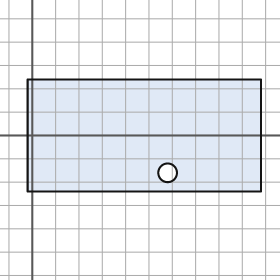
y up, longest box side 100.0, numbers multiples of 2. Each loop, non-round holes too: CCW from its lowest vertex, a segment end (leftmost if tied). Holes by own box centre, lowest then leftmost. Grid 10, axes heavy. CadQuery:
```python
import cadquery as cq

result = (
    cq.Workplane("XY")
    .moveTo(-2.0, -24.0)
    .lineTo(98.0, -24.0)
    .lineTo(98.0, 24.0)
    .lineTo(-2.0, 24.0)
    .close()
    .moveTo(58.0, -16.0)
    .circle(4.0)
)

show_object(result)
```